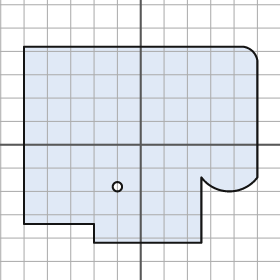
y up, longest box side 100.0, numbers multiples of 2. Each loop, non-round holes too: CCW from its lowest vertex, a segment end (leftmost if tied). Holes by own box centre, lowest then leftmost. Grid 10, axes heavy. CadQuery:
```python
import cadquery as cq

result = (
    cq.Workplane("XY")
    .moveTo(-20.0, -42.0)
    .lineTo(26.0, -42.0)
    .lineTo(26.0, -14.0)
    .threePointArc((38.0, -20.0), (50.0, -14.0))
    .lineTo(50.0, 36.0)
    .threePointArc((48.0, 40.0), (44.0, 42.0))
    .lineTo(-50.0, 42.0)
    .lineTo(-50.0, -34.0)
    .lineTo(-20.0, -34.0)
    .close()
    .moveTo(-10.0, -18.0)
    .circle(2.0)
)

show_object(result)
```